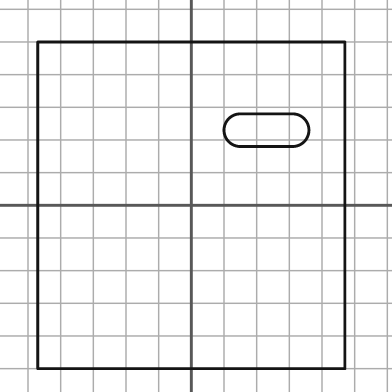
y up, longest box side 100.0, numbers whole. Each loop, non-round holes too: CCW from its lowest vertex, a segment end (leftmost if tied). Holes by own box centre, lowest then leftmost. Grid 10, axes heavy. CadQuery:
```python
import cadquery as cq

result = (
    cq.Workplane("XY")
    .moveTo(-47.0, -50.0)
    .lineTo(47.0, -50.0)
    .lineTo(47.0, 50.0)
    .lineTo(-47.0, 50.0)
    .close()
    .moveTo(15.0, 18.0)
    .lineTo(31.0, 18.0)
    .threePointArc((36.0, 23.0), (31.0, 28.0))
    .lineTo(15.0, 28.0)
    .threePointArc((10.0, 23.0), (15.0, 18.0))
    .close()
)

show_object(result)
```